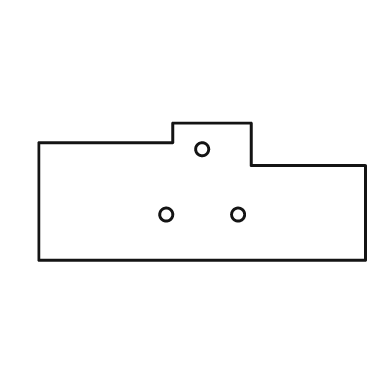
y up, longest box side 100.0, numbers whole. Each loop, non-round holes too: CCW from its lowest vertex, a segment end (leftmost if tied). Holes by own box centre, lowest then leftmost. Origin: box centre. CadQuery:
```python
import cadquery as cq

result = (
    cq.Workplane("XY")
    .moveTo(-50.0, -21.0)
    .lineTo(50.0, -21.0)
    .lineTo(50.0, 8.0)
    .lineTo(15.0, 8.0)
    .lineTo(15.0, 21.0)
    .lineTo(-9.0, 21.0)
    .lineTo(-9.0, 15.0)
    .lineTo(-50.0, 15.0)
    .close()
    .moveTo(-11.0, -7.0)
    .circle(2.0)
    .moveTo(11.0, -7.0)
    .circle(2.0)
    .moveTo(0.0, 13.0)
    .circle(2.0)
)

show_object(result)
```